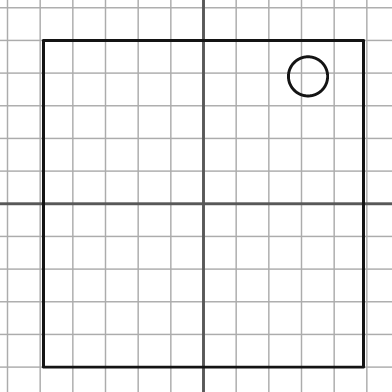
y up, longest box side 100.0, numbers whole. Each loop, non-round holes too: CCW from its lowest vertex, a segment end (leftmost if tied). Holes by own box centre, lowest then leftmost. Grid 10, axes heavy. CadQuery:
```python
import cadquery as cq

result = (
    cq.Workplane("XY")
    .moveTo(-49.0, -50.0)
    .lineTo(49.0, -50.0)
    .lineTo(49.0, 50.0)
    .lineTo(-49.0, 50.0)
    .close()
    .moveTo(32.0, 39.0)
    .circle(6.0)
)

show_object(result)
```